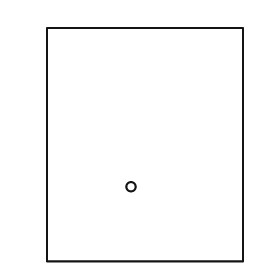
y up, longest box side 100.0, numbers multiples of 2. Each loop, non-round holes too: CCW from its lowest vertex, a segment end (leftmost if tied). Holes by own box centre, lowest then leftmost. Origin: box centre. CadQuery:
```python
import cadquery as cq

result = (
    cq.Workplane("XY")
    .moveTo(-42.0, -50.0)
    .lineTo(42.0, -50.0)
    .lineTo(42.0, 50.0)
    .lineTo(-42.0, 50.0)
    .close()
    .moveTo(-6.0, -18.0)
    .circle(2.0)
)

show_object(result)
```